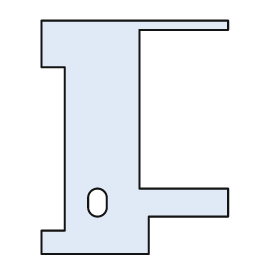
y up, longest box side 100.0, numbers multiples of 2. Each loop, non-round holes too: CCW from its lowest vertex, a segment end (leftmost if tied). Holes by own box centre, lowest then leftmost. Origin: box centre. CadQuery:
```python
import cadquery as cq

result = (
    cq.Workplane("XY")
    .moveTo(-40.0, -50.0)
    .lineTo(6.0, -50.0)
    .lineTo(6.0, -34.0)
    .lineTo(40.0, -34.0)
    .lineTo(40.0, -22.0)
    .lineTo(2.0, -22.0)
    .lineTo(2.0, 46.0)
    .lineTo(40.0, 46.0)
    .lineTo(40.0, 50.0)
    .lineTo(-40.0, 50.0)
    .lineTo(-40.0, 30.0)
    .lineTo(-30.0, 30.0)
    .lineTo(-30.0, -40.0)
    .lineTo(-40.0, -40.0)
    .close()
    .moveTo(-20.0, -30.0)
    .threePointArc((-16.0, -34.0), (-12.0, -30.0))
    .lineTo(-12.0, -26.0)
    .threePointArc((-16.0, -22.0), (-20.0, -26.0))
    .close()
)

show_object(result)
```